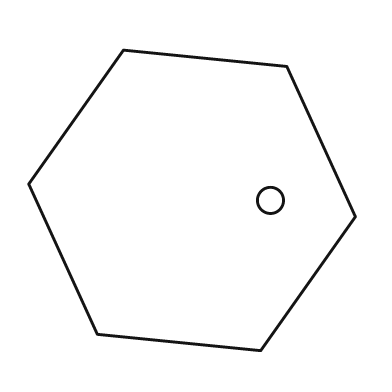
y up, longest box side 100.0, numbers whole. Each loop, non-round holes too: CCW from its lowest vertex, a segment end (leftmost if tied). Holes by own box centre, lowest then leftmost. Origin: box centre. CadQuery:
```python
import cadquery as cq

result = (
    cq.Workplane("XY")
    .moveTo(21.0, -46.0)
    .lineTo(50.0, -5.0)
    .lineTo(29.0, 41.0)
    .lineTo(-21.0, 46.0)
    .lineTo(-50.0, 5.0)
    .lineTo(-29.0, -41.0)
    .close()
    .moveTo(24.0, 0.0)
    .circle(4.0)
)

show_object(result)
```